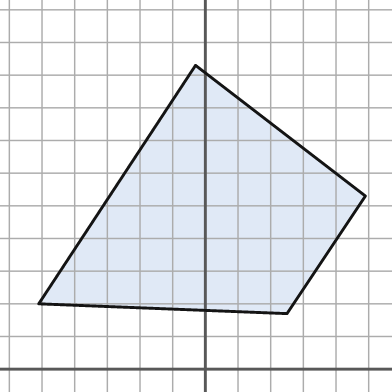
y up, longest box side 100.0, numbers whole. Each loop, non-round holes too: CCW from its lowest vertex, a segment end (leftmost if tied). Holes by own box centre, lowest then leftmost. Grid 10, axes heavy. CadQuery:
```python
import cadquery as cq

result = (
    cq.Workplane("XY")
    .moveTo(25.0, 17.0)
    .lineTo(49.0, 53.0)
    .lineTo(-3.0, 93.0)
    .lineTo(-51.0, 20.0)
    .close()
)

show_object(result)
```